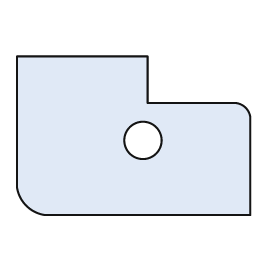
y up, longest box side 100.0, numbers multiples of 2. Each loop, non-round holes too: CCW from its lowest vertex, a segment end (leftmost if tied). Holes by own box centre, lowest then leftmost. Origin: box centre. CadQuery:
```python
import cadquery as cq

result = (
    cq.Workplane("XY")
    .moveTo(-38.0, -34.0)
    .lineTo(50.0, -34.0)
    .lineTo(50.0, 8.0)
    .threePointArc((48.0, 12.0), (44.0, 14.0))
    .lineTo(6.0, 14.0)
    .lineTo(6.0, 34.0)
    .lineTo(-50.0, 34.0)
    .lineTo(-50.0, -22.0)
    .threePointArc((-46.0, -30.0), (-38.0, -34.0))
    .close()
    .moveTo(4.0, -2.0)
    .circle(8.0)
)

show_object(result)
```